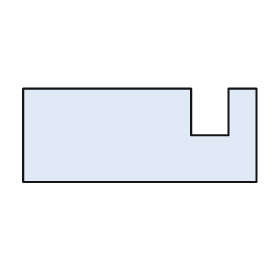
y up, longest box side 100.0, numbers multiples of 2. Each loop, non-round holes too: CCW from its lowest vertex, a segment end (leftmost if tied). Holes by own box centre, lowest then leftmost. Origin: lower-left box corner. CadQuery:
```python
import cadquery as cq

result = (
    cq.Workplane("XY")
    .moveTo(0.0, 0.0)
    .lineTo(100.0, 0.0)
    .lineTo(100.0, 40.0)
    .lineTo(88.0, 40.0)
    .lineTo(88.0, 20.0)
    .lineTo(72.0, 20.0)
    .lineTo(72.0, 40.0)
    .lineTo(0.0, 40.0)
    .close()
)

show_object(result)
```